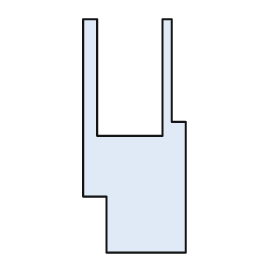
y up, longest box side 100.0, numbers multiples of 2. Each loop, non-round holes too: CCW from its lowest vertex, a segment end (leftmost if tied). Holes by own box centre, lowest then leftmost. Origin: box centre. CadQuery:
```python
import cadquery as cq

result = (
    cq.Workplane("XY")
    .moveTo(-12.0, -50.0)
    .lineTo(22.0, -50.0)
    .lineTo(22.0, 6.0)
    .lineTo(16.0, 6.0)
    .lineTo(16.0, 50.0)
    .lineTo(12.0, 50.0)
    .lineTo(12.0, 0.0)
    .lineTo(-16.0, 0.0)
    .lineTo(-16.0, 50.0)
    .lineTo(-22.0, 50.0)
    .lineTo(-22.0, -26.0)
    .lineTo(-12.0, -26.0)
    .close()
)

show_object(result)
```